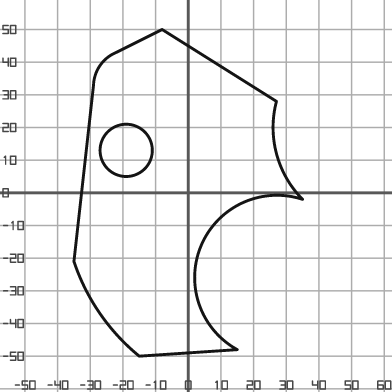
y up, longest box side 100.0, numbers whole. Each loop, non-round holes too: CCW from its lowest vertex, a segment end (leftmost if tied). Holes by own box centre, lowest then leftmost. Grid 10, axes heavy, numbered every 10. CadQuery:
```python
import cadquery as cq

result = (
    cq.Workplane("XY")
    .moveTo(-15.0, -50.0)
    .lineTo(15.0, -48.0)
    .threePointArc((4.0, -16.0), (35.0, -2.0))
    .threePointArc((27.0, 12.0), (27.0, 28.0))
    .lineTo(-8.0, 50.0)
    .lineTo(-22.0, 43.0)
    .threePointArc((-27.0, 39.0), (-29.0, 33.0))
    .lineTo(-35.0, -21.0)
    .threePointArc((-27.0, -37.0), (-15.0, -50.0))
    .close()
    .moveTo(-19.0, 13.0)
    .circle(8.0)
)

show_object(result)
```